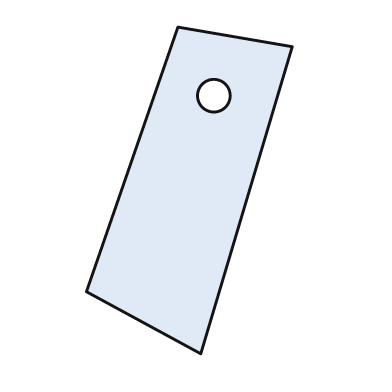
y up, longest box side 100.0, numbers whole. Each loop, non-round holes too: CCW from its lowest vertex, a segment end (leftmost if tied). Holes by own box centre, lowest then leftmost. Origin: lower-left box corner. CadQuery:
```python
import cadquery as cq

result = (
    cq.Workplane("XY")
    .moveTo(35.0, 0.0)
    .lineTo(63.0, 94.0)
    .lineTo(28.0, 100.0)
    .lineTo(0.0, 19.0)
    .close()
    .moveTo(39.0, 79.0)
    .circle(5.0)
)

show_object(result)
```